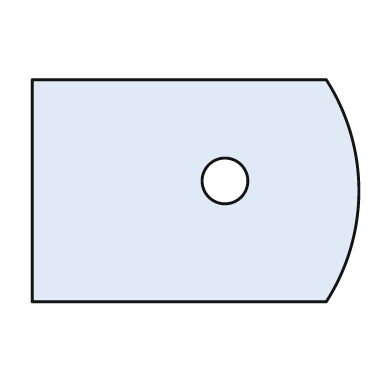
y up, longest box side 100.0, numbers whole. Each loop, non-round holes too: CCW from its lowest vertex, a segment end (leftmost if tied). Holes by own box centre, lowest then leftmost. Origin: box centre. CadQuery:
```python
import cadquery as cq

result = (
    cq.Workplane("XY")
    .moveTo(-50.0, -34.0)
    .lineTo(40.0, -34.0)
    .threePointArc((50.0, 0.0), (40.0, 34.0))
    .lineTo(-50.0, 34.0)
    .close()
    .moveTo(9.0, 3.0)
    .circle(7.0)
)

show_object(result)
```